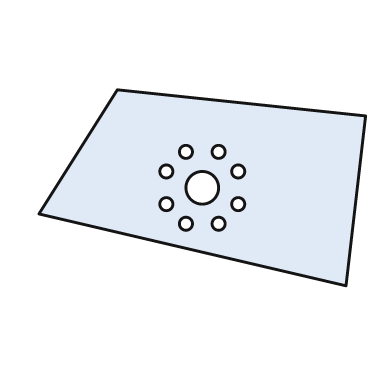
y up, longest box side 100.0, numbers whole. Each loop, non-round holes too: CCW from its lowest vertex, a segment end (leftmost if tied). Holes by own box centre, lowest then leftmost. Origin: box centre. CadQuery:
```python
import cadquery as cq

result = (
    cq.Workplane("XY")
    .moveTo(44.0, -30.0)
    .lineTo(50.0, 22.0)
    .lineTo(-26.0, 30.0)
    .lineTo(-50.0, -8.0)
    .close()
    .moveTo(-5.0, -11.0)
    .circle(2.0)
    .moveTo(5.0, -11.0)
    .circle(2.0)
    .moveTo(-11.0, -5.0)
    .circle(2.0)
    .moveTo(11.0, -5.0)
    .circle(2.0)
    .moveTo(0.0, 0.0)
    .circle(5.0)
    .moveTo(-11.0, 5.0)
    .circle(2.0)
    .moveTo(11.0, 5.0)
    .circle(2.0)
    .moveTo(-5.0, 11.0)
    .circle(2.0)
    .moveTo(5.0, 11.0)
    .circle(2.0)
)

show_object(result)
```